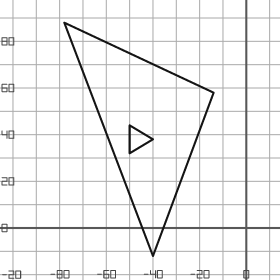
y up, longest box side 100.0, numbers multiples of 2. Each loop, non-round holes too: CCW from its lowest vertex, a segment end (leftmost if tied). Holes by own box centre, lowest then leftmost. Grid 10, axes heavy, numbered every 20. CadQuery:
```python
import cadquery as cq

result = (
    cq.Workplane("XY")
    .moveTo(-40.0, -12.0)
    .lineTo(-14.0, 58.0)
    .lineTo(-78.0, 88.0)
    .close()
    .moveTo(-50.0, 32.0)
    .lineTo(-40.0, 38.0)
    .lineTo(-50.0, 44.0)
    .close()
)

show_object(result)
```